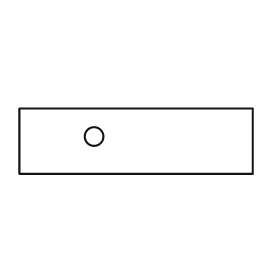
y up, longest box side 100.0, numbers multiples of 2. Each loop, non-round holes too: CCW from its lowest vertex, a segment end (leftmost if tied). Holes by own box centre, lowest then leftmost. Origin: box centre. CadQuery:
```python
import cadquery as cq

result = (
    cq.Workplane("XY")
    .moveTo(-50.0, -14.0)
    .lineTo(50.0, -14.0)
    .lineTo(50.0, 14.0)
    .lineTo(-50.0, 14.0)
    .close()
    .moveTo(-18.0, 2.0)
    .circle(4.0)
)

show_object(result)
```